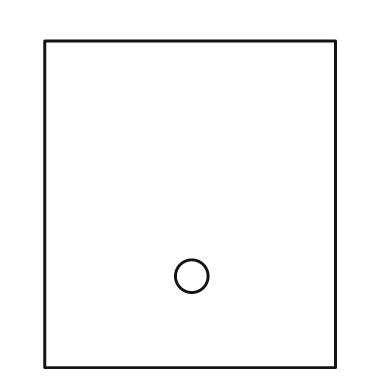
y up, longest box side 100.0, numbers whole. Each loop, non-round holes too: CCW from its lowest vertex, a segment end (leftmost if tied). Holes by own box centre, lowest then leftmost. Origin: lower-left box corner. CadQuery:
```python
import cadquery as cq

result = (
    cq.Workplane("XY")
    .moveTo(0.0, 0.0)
    .lineTo(89.0, 0.0)
    .lineTo(89.0, 100.0)
    .lineTo(0.0, 100.0)
    .close()
    .moveTo(45.0, 28.0)
    .circle(5.0)
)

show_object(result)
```